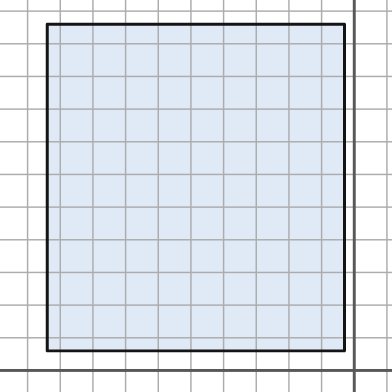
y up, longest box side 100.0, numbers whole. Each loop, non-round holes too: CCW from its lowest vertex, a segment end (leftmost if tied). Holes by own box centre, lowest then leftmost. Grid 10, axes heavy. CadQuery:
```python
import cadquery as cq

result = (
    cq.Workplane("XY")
    .moveTo(-94.0, 6.0)
    .lineTo(-3.0, 6.0)
    .lineTo(-3.0, 106.0)
    .lineTo(-94.0, 106.0)
    .close()
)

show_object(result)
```